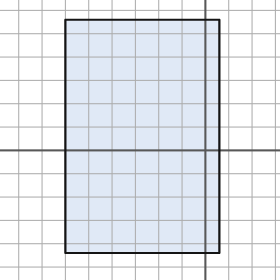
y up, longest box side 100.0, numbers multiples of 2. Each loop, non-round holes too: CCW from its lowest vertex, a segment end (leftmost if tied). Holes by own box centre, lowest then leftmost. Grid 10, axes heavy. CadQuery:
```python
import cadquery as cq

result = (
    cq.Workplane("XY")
    .moveTo(-60.0, -44.0)
    .lineTo(6.0, -44.0)
    .lineTo(6.0, 56.0)
    .lineTo(-60.0, 56.0)
    .close()
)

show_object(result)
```